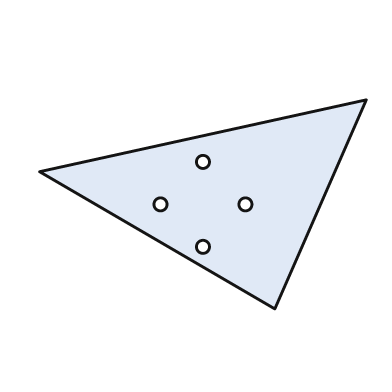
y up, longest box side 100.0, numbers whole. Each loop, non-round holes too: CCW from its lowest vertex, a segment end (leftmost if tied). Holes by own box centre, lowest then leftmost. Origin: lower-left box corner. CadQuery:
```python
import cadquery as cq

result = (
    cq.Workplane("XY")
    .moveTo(72.0, 0.0)
    .lineTo(100.0, 64.0)
    .lineTo(0.0, 42.0)
    .close()
    .moveTo(50.0, 19.0)
    .circle(2.0)
    .moveTo(37.0, 32.0)
    .circle(2.0)
    .moveTo(63.0, 32.0)
    .circle(2.0)
    .moveTo(50.0, 45.0)
    .circle(2.0)
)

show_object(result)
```